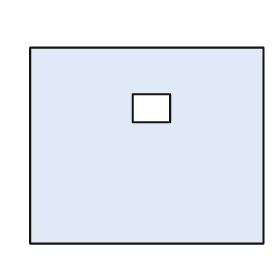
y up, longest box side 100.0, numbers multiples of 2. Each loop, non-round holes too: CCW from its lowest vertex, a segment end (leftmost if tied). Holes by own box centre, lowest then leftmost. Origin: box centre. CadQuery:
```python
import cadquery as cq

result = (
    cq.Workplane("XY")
    .moveTo(-50.0, -42.0)
    .lineTo(50.0, -42.0)
    .lineTo(50.0, 42.0)
    .lineTo(-50.0, 42.0)
    .close()
    .moveTo(-6.0, 10.0)
    .lineTo(10.0, 10.0)
    .lineTo(10.0, 22.0)
    .lineTo(-6.0, 22.0)
    .close()
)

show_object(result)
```